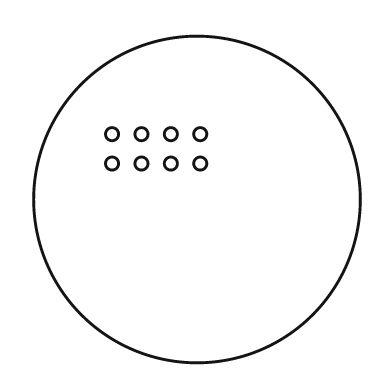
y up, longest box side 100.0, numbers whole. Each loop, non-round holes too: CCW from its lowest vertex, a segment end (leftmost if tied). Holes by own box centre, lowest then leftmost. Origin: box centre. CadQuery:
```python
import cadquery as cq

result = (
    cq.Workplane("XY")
    .moveTo(0.0, 0.0)
    .circle(50.0)
    .moveTo(-26.0, 11.0)
    .circle(2.0)
    .moveTo(-17.0, 11.0)
    .circle(2.0)
    .moveTo(-8.0, 11.0)
    .circle(2.0)
    .moveTo(1.0, 11.0)
    .circle(2.0)
    .moveTo(-26.0, 20.0)
    .circle(2.0)
    .moveTo(-17.0, 20.0)
    .circle(2.0)
    .moveTo(-8.0, 20.0)
    .circle(2.0)
    .moveTo(1.0, 20.0)
    .circle(2.0)
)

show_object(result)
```